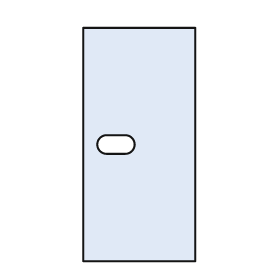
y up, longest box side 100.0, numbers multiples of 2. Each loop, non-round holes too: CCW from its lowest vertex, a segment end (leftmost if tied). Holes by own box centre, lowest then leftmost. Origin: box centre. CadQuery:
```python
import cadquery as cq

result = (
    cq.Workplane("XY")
    .moveTo(-24.0, -50.0)
    .lineTo(24.0, -50.0)
    .lineTo(24.0, 50.0)
    .lineTo(-24.0, 50.0)
    .close()
    .moveTo(-14.0, -4.0)
    .lineTo(-6.0, -4.0)
    .threePointArc((-2.0, 0.0), (-6.0, 4.0))
    .lineTo(-14.0, 4.0)
    .threePointArc((-18.0, 0.0), (-14.0, -4.0))
    .close()
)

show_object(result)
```